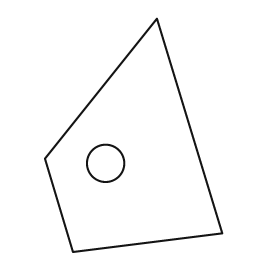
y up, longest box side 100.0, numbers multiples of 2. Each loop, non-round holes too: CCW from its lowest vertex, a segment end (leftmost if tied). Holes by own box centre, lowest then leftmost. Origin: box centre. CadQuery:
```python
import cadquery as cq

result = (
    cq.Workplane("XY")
    .moveTo(-26.0, -50.0)
    .lineTo(38.0, -42.0)
    .lineTo(10.0, 50.0)
    .lineTo(-38.0, -10.0)
    .close()
    .moveTo(-12.0, -12.0)
    .circle(8.0)
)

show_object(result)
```